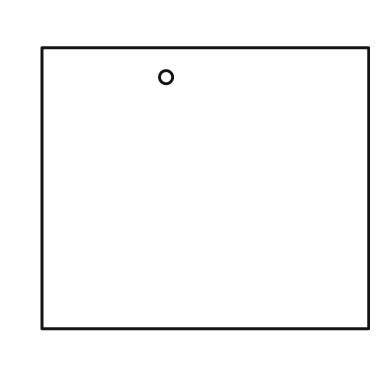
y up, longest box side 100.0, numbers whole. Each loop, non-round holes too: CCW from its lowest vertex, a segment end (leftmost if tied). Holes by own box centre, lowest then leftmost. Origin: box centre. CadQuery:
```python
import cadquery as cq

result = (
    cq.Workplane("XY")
    .moveTo(-50.0, -43.0)
    .lineTo(50.0, -43.0)
    .lineTo(50.0, 43.0)
    .lineTo(-50.0, 43.0)
    .close()
    .moveTo(-12.0, 34.0)
    .circle(2.0)
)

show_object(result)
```